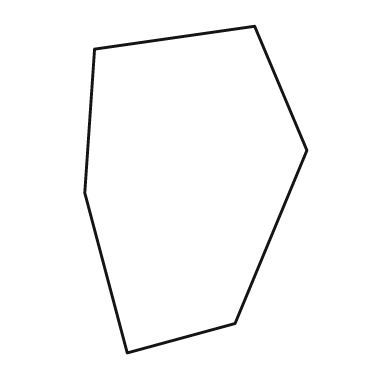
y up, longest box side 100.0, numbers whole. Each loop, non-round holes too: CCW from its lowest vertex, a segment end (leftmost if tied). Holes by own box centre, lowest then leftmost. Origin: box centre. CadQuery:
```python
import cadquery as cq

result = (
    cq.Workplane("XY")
    .moveTo(-21.0, -50.0)
    .lineTo(12.0, -41.0)
    .lineTo(34.0, 12.0)
    .lineTo(18.0, 50.0)
    .lineTo(-31.0, 43.0)
    .lineTo(-34.0, -1.0)
    .close()
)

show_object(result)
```